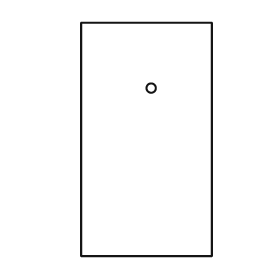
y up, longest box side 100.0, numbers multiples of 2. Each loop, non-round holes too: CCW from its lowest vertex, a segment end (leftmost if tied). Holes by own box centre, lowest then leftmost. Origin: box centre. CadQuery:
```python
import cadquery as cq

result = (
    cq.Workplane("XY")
    .moveTo(-28.0, -50.0)
    .lineTo(28.0, -50.0)
    .lineTo(28.0, 50.0)
    .lineTo(-28.0, 50.0)
    .close()
    .moveTo(2.0, 22.0)
    .circle(2.0)
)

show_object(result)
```